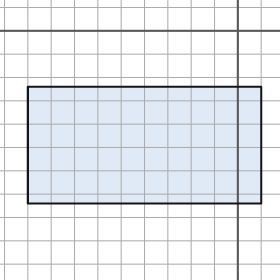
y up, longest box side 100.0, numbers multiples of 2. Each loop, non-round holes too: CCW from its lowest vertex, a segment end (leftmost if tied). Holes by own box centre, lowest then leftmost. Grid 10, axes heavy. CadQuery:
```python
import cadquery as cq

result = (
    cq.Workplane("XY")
    .moveTo(-90.0, -74.0)
    .lineTo(10.0, -74.0)
    .lineTo(10.0, -24.0)
    .lineTo(-90.0, -24.0)
    .close()
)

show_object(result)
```